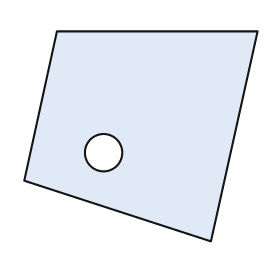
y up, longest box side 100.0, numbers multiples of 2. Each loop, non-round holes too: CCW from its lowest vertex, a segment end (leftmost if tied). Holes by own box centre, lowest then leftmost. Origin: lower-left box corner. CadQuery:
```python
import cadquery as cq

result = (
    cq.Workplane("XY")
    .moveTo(80.0, 0.0)
    .lineTo(100.0, 90.0)
    .lineTo(14.0, 90.0)
    .lineTo(0.0, 26.0)
    .close()
    .moveTo(34.0, 38.0)
    .circle(8.0)
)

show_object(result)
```